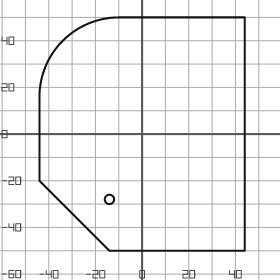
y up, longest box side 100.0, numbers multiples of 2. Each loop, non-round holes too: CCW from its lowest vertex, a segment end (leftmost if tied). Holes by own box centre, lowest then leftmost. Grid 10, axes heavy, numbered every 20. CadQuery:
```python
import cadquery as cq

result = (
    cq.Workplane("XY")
    .moveTo(-14.0, -50.0)
    .lineTo(44.0, -50.0)
    .lineTo(44.0, 50.0)
    .lineTo(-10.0, 50.0)
    .threePointArc((-34.0, 40.0), (-44.0, 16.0))
    .lineTo(-44.0, -20.0)
    .close()
    .moveTo(-14.0, -28.0)
    .circle(2.0)
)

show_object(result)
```